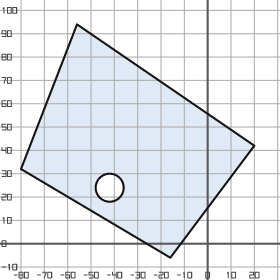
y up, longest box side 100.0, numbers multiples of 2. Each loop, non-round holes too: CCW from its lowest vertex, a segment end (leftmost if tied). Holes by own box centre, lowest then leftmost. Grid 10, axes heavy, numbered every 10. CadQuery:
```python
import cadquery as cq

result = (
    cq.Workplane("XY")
    .moveTo(-16.0, -6.0)
    .lineTo(20.0, 42.0)
    .lineTo(-56.0, 94.0)
    .lineTo(-80.0, 32.0)
    .close()
    .moveTo(-42.0, 24.0)
    .circle(6.0)
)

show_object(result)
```